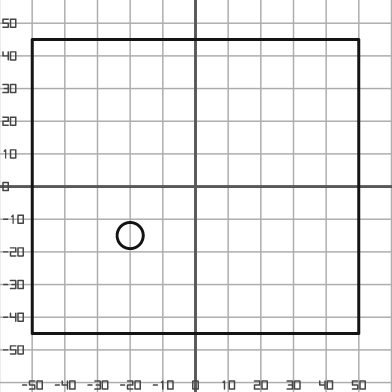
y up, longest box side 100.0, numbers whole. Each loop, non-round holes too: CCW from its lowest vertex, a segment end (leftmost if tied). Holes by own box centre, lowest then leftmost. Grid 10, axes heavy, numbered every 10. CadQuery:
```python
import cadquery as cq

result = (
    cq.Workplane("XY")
    .moveTo(-50.0, -45.0)
    .lineTo(50.0, -45.0)
    .lineTo(50.0, 45.0)
    .lineTo(-50.0, 45.0)
    .close()
    .moveTo(-20.0, -15.0)
    .circle(4.0)
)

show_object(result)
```